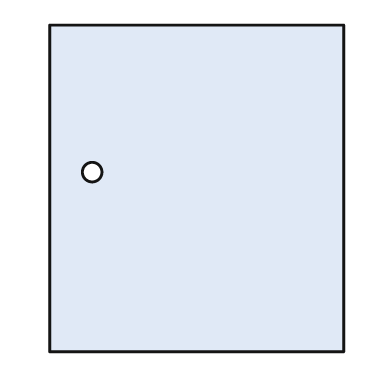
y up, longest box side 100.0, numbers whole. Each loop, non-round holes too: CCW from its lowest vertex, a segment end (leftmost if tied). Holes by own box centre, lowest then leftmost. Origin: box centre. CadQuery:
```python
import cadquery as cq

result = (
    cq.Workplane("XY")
    .moveTo(-45.0, -50.0)
    .lineTo(45.0, -50.0)
    .lineTo(45.0, 50.0)
    .lineTo(-45.0, 50.0)
    .close()
    .moveTo(-32.0, 5.0)
    .circle(3.0)
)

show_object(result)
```